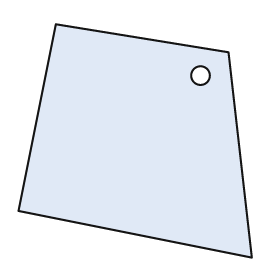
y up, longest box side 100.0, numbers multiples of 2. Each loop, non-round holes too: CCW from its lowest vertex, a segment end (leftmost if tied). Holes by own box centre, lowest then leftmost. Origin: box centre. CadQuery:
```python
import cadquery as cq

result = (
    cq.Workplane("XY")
    .moveTo(50.0, -50.0)
    .lineTo(40.0, 38.0)
    .lineTo(-34.0, 50.0)
    .lineTo(-50.0, -30.0)
    .close()
    .moveTo(28.0, 28.0)
    .circle(4.0)
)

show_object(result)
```